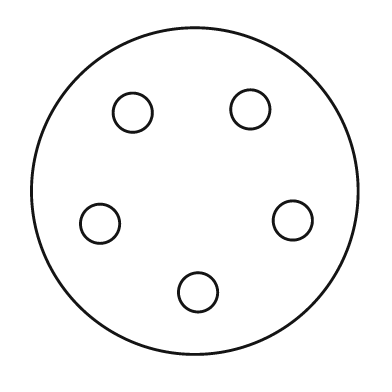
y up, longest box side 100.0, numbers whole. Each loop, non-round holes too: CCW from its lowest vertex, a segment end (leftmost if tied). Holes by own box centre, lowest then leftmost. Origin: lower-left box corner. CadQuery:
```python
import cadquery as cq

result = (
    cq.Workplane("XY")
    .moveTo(50.0, 50.0)
    .circle(50.0)
    .moveTo(51.0, 19.0)
    .circle(6.0)
    .moveTo(21.0, 40.0)
    .circle(6.0)
    .moveTo(80.0, 41.0)
    .circle(6.0)
    .moveTo(31.0, 74.0)
    .circle(6.0)
    .moveTo(67.0, 75.0)
    .circle(6.0)
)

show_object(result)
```